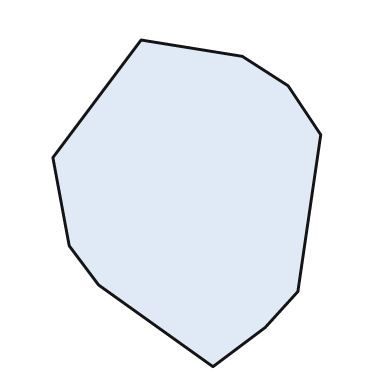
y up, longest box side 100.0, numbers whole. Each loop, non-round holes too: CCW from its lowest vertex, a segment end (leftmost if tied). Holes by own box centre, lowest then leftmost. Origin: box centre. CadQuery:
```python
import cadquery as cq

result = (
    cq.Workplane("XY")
    .moveTo(8.0, -50.0)
    .lineTo(24.0, -38.0)
    .lineTo(34.0, -27.0)
    .lineTo(41.0, 21.0)
    .lineTo(31.0, 36.0)
    .lineTo(17.0, 45.0)
    .lineTo(-14.0, 50.0)
    .lineTo(-41.0, 14.0)
    .lineTo(-36.0, -13.0)
    .lineTo(-27.0, -25.0)
    .close()
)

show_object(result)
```